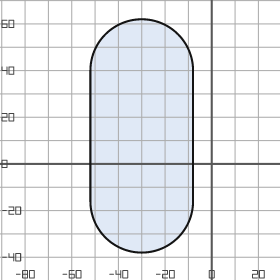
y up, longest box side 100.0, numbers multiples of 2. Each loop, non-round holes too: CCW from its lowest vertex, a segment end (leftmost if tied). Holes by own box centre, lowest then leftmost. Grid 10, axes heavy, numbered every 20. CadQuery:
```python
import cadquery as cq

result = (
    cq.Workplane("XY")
    .moveTo(-52.0, -16.0)
    .threePointArc((-30.0, -38.0), (-8.0, -16.0))
    .lineTo(-8.0, 40.0)
    .threePointArc((-30.0, 62.0), (-52.0, 40.0))
    .close()
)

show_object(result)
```